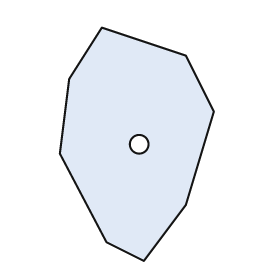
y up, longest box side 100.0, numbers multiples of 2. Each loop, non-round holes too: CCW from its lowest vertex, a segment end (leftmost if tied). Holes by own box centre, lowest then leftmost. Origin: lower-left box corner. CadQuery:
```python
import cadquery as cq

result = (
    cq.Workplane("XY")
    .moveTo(36.0, 0.0)
    .lineTo(54.0, 24.0)
    .lineTo(66.0, 64.0)
    .lineTo(54.0, 88.0)
    .lineTo(18.0, 100.0)
    .lineTo(4.0, 78.0)
    .lineTo(0.0, 46.0)
    .lineTo(20.0, 8.0)
    .close()
    .moveTo(34.0, 50.0)
    .circle(4.0)
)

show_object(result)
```